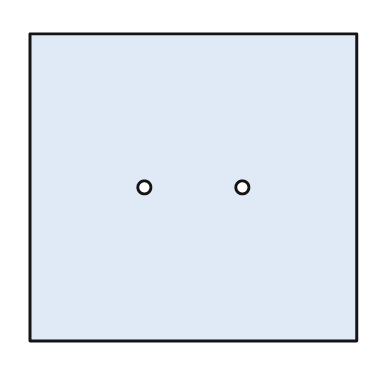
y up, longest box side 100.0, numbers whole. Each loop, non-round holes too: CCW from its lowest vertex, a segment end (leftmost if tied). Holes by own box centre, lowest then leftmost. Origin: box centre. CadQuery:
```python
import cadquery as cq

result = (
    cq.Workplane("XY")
    .moveTo(-50.0, -47.0)
    .lineTo(50.0, -47.0)
    .lineTo(50.0, 47.0)
    .lineTo(-50.0, 47.0)
    .close()
    .moveTo(-15.0, 0.0)
    .circle(2.0)
    .moveTo(15.0, 0.0)
    .circle(2.0)
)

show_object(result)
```